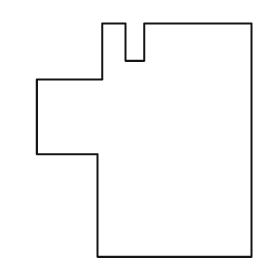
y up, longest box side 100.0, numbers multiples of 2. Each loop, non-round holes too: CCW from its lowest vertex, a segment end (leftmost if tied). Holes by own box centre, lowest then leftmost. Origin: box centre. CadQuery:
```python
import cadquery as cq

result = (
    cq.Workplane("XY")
    .moveTo(-20.0, -50.0)
    .lineTo(46.0, -50.0)
    .lineTo(46.0, 50.0)
    .lineTo(0.0, 50.0)
    .lineTo(0.0, 34.0)
    .lineTo(-8.0, 34.0)
    .lineTo(-8.0, 50.0)
    .lineTo(-18.0, 50.0)
    .lineTo(-18.0, 26.0)
    .lineTo(-46.0, 26.0)
    .lineTo(-46.0, -6.0)
    .lineTo(-20.0, -6.0)
    .close()
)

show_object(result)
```